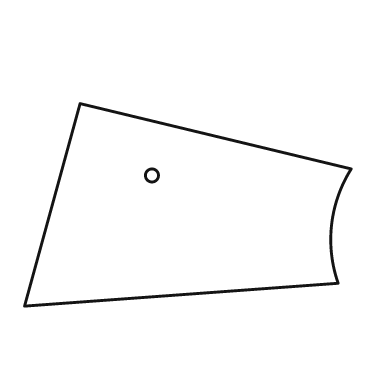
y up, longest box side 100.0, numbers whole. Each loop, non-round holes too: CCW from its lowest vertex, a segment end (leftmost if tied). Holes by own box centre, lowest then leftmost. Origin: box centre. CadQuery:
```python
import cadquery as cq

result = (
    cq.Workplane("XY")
    .moveTo(-50.0, -31.0)
    .lineTo(46.0, -24.0)
    .threePointArc((44.0, -6.0), (50.0, 11.0))
    .lineTo(-33.0, 31.0)
    .close()
    .moveTo(-11.0, 9.0)
    .circle(2.0)
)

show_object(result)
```